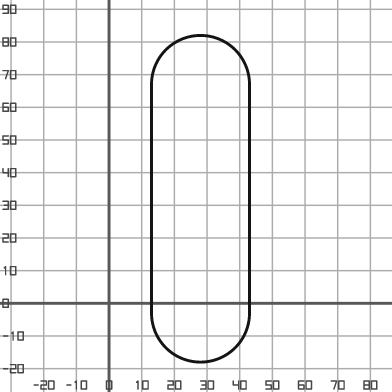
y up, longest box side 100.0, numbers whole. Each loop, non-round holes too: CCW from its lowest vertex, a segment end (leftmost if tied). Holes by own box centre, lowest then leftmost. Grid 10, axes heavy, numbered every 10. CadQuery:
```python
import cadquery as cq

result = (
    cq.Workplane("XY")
    .moveTo(13.0, -3.0)
    .threePointArc((28.0, -18.0), (43.0, -3.0))
    .lineTo(43.0, 67.0)
    .threePointArc((28.0, 82.0), (13.0, 67.0))
    .close()
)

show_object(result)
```